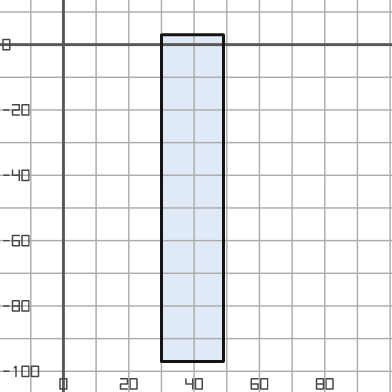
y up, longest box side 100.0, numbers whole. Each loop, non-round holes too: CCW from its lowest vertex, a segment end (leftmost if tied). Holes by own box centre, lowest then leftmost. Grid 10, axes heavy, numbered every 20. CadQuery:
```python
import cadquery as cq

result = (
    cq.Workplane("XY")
    .moveTo(30.0, -97.0)
    .lineTo(49.0, -97.0)
    .lineTo(49.0, 3.0)
    .lineTo(30.0, 3.0)
    .close()
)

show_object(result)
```